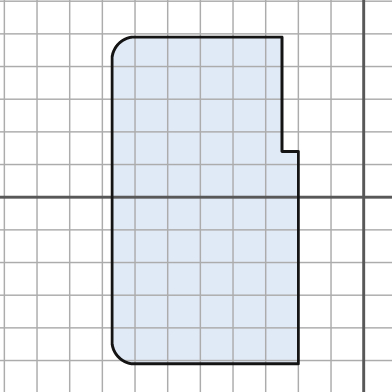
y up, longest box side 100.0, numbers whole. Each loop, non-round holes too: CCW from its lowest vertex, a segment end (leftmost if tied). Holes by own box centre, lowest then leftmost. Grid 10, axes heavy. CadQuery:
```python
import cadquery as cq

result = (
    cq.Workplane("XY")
    .moveTo(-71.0, -51.0)
    .lineTo(-20.0, -51.0)
    .lineTo(-20.0, 14.0)
    .lineTo(-25.0, 14.0)
    .lineTo(-25.0, 49.0)
    .lineTo(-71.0, 49.0)
    .threePointArc((-75.0, 47.0), (-77.0, 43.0))
    .lineTo(-77.0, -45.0)
    .threePointArc((-75.0, -49.0), (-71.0, -51.0))
    .close()
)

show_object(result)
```